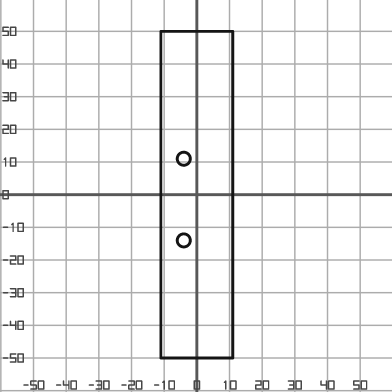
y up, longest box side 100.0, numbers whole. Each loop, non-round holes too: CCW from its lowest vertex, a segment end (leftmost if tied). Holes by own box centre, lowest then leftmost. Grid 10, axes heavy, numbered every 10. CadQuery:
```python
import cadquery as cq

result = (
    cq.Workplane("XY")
    .moveTo(-11.0, -50.0)
    .lineTo(11.0, -50.0)
    .lineTo(11.0, 50.0)
    .lineTo(-11.0, 50.0)
    .close()
    .moveTo(-4.0, -14.0)
    .circle(2.0)
    .moveTo(-4.0, 11.0)
    .circle(2.0)
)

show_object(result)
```